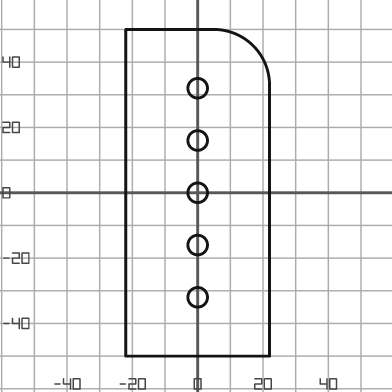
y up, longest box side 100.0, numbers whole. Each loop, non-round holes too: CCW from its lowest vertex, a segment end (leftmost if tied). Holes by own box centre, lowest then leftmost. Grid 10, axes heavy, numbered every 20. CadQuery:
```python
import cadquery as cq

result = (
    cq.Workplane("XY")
    .moveTo(-22.0, -50.0)
    .lineTo(22.0, -50.0)
    .lineTo(22.0, 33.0)
    .threePointArc((17.0, 45.0), (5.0, 50.0))
    .lineTo(-22.0, 50.0)
    .close()
    .moveTo(0.0, -32.0)
    .circle(3.0)
    .moveTo(0.0, -16.0)
    .circle(3.0)
    .moveTo(0.0, 0.0)
    .circle(3.0)
    .moveTo(0.0, 16.0)
    .circle(3.0)
    .moveTo(0.0, 32.0)
    .circle(3.0)
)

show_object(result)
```